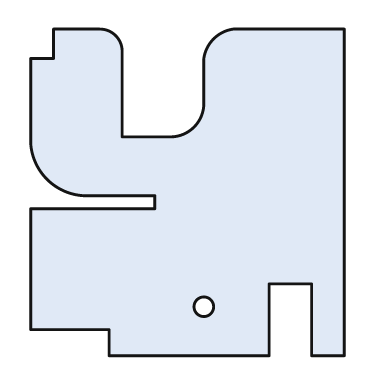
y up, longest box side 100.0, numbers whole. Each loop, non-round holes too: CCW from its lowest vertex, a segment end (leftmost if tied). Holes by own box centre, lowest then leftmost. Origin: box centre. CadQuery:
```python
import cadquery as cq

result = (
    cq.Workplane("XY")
    .moveTo(-24.0, -50.0)
    .lineTo(25.0, -50.0)
    .lineTo(25.0, -28.0)
    .lineTo(38.0, -28.0)
    .lineTo(38.0, -50.0)
    .lineTo(48.0, -50.0)
    .lineTo(48.0, 50.0)
    .lineTo(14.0, 50.0)
    .threePointArc((8.0, 47.0), (5.0, 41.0))
    .lineTo(5.0, 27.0)
    .threePointArc((2.0, 20.0), (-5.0, 17.0))
    .lineTo(-20.0, 17.0)
    .lineTo(-20.0, 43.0)
    .threePointArc((-22.0, 48.0), (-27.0, 50.0))
    .lineTo(-41.0, 50.0)
    .lineTo(-41.0, 41.0)
    .lineTo(-48.0, 41.0)
    .lineTo(-48.0, 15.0)
    .threePointArc((-43.0, 4.0), (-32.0, -1.0))
    .lineTo(-10.0, -1.0)
    .lineTo(-10.0, -5.0)
    .lineTo(-48.0, -5.0)
    .lineTo(-48.0, -42.0)
    .lineTo(-24.0, -42.0)
    .close()
    .moveTo(5.0, -35.0)
    .circle(3.0)
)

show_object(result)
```